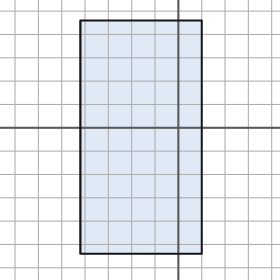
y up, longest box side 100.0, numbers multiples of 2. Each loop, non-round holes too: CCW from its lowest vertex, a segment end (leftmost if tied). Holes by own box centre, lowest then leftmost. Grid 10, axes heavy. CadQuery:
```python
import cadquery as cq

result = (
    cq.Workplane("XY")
    .moveTo(-42.0, -54.0)
    .lineTo(10.0, -54.0)
    .lineTo(10.0, 46.0)
    .lineTo(-42.0, 46.0)
    .close()
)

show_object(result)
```